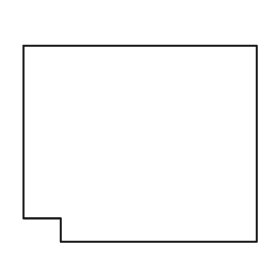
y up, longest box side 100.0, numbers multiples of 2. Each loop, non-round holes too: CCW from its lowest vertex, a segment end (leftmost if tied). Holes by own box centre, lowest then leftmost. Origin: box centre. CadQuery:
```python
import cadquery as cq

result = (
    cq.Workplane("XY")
    .moveTo(-34.0, -42.0)
    .lineTo(50.0, -42.0)
    .lineTo(50.0, 42.0)
    .lineTo(-50.0, 42.0)
    .lineTo(-50.0, -32.0)
    .lineTo(-34.0, -32.0)
    .close()
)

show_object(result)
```